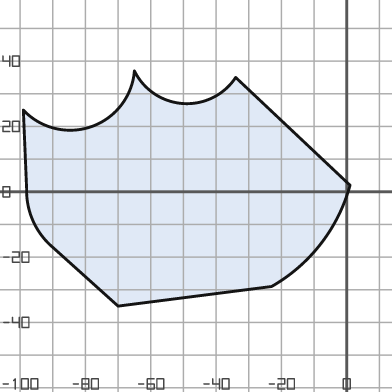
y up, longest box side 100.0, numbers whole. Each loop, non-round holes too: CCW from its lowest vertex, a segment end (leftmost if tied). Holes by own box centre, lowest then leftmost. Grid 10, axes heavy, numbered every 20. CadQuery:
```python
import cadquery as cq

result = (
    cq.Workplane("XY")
    .moveTo(-70.0, -35.0)
    .lineTo(-23.0, -29.0)
    .threePointArc((-8.0, -16.0), (1.0, 2.0))
    .lineTo(-34.0, 35.0)
    .threePointArc((-50.0, 27.0), (-65.0, 37.0))
    .threePointArc((-78.0, 20.0), (-99.0, 25.0))
    .lineTo(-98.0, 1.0)
    .threePointArc((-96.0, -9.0), (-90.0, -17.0))
    .close()
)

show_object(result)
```